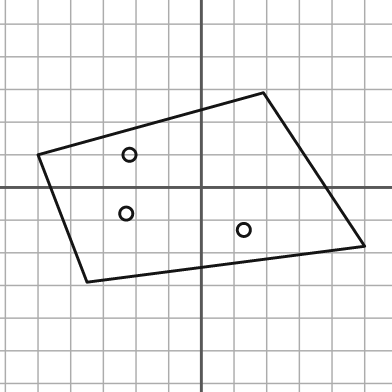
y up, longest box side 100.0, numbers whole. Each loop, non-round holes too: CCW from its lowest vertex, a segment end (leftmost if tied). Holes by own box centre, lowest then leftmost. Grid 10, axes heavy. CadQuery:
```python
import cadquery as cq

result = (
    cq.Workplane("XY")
    .moveTo(-35.0, -29.0)
    .lineTo(50.0, -18.0)
    .lineTo(19.0, 29.0)
    .lineTo(-50.0, 10.0)
    .close()
    .moveTo(13.0, -13.0)
    .circle(2.0)
    .moveTo(-23.0, -8.0)
    .circle(2.0)
    .moveTo(-22.0, 10.0)
    .circle(2.0)
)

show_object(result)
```